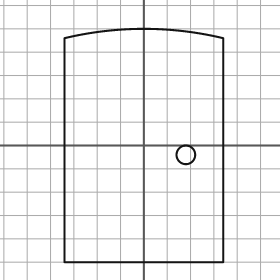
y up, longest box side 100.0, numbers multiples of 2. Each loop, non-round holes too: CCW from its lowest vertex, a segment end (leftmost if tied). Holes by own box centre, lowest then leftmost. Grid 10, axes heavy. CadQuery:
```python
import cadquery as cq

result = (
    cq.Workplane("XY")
    .moveTo(-34.0, -50.0)
    .lineTo(34.0, -50.0)
    .lineTo(34.0, 46.0)
    .threePointArc((0.0, 50.0), (-34.0, 46.0))
    .close()
    .moveTo(18.0, -4.0)
    .circle(4.0)
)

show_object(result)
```